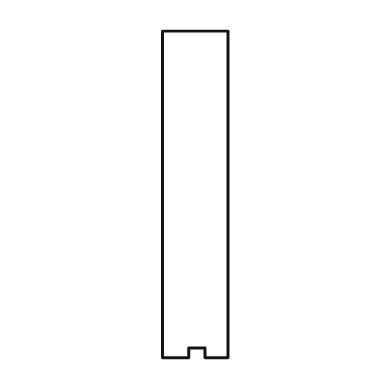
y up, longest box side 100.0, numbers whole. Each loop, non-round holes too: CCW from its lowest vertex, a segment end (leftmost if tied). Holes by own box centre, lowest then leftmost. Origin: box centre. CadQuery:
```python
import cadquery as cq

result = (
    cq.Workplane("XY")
    .moveTo(-10.0, -50.0)
    .lineTo(-2.0, -50.0)
    .lineTo(-2.0, -47.0)
    .lineTo(3.0, -47.0)
    .lineTo(3.0, -50.0)
    .lineTo(10.0, -50.0)
    .lineTo(10.0, 50.0)
    .lineTo(-10.0, 50.0)
    .close()
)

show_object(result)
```